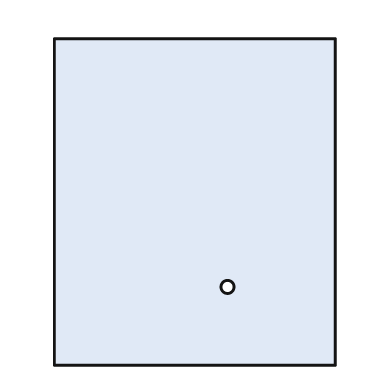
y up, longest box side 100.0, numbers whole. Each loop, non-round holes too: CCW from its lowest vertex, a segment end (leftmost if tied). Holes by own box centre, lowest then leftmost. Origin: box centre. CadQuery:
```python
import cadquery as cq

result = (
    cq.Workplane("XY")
    .moveTo(-43.0, -50.0)
    .lineTo(43.0, -50.0)
    .lineTo(43.0, 50.0)
    .lineTo(-43.0, 50.0)
    .close()
    .moveTo(10.0, -26.0)
    .circle(2.0)
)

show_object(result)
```